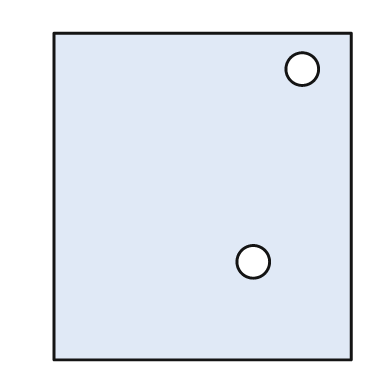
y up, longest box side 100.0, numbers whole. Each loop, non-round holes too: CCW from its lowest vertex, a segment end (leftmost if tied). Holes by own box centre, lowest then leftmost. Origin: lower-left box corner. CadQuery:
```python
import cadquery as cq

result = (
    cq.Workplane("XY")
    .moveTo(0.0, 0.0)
    .lineTo(91.0, 0.0)
    .lineTo(91.0, 100.0)
    .lineTo(0.0, 100.0)
    .close()
    .moveTo(61.0, 30.0)
    .circle(5.0)
    .moveTo(76.0, 89.0)
    .circle(5.0)
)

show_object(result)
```